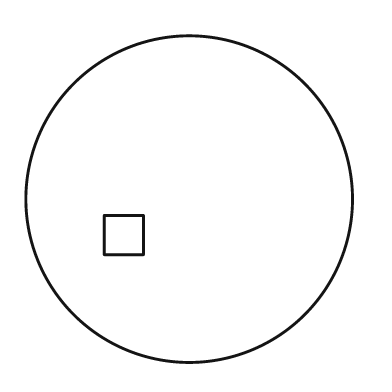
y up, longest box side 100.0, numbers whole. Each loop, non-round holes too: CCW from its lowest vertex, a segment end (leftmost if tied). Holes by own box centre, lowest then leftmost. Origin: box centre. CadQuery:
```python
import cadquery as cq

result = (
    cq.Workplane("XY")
    .moveTo(0.0, 0.0)
    .circle(50.0)
    .moveTo(-26.0, -17.0)
    .lineTo(-14.0, -17.0)
    .lineTo(-14.0, -5.0)
    .lineTo(-26.0, -5.0)
    .close()
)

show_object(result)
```